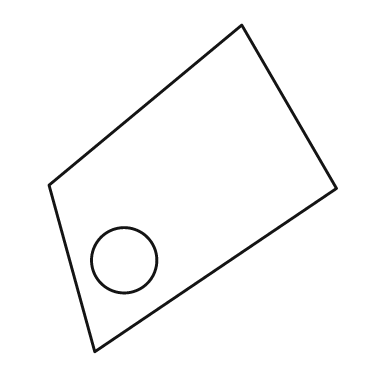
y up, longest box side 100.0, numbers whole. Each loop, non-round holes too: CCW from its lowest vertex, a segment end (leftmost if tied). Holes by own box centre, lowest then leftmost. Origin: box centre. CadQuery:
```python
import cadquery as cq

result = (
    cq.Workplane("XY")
    .moveTo(-30.0, -50.0)
    .lineTo(44.0, 0.0)
    .lineTo(15.0, 50.0)
    .lineTo(-44.0, 1.0)
    .close()
    .moveTo(-21.0, -22.0)
    .circle(10.0)
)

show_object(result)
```